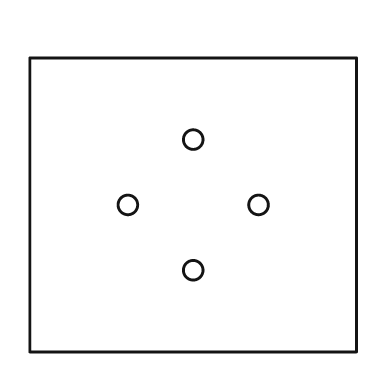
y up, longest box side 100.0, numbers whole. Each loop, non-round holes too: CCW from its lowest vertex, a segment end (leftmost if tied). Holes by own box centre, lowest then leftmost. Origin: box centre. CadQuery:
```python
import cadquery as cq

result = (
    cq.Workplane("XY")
    .moveTo(-50.0, -45.0)
    .lineTo(50.0, -45.0)
    .lineTo(50.0, 45.0)
    .lineTo(-50.0, 45.0)
    .close()
    .moveTo(0.0, -20.0)
    .circle(3.0)
    .moveTo(-20.0, 0.0)
    .circle(3.0)
    .moveTo(20.0, 0.0)
    .circle(3.0)
    .moveTo(0.0, 20.0)
    .circle(3.0)
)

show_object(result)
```